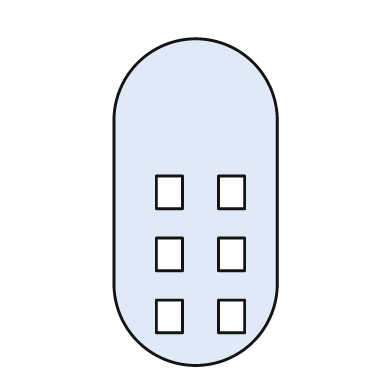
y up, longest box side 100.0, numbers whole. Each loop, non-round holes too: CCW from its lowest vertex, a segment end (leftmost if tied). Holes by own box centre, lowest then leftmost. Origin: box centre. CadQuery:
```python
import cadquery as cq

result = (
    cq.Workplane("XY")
    .moveTo(-25.0, -25.0)
    .threePointArc((0.0, -50.0), (25.0, -25.0))
    .lineTo(25.0, 25.0)
    .threePointArc((0.0, 50.0), (-25.0, 25.0))
    .close()
    .moveTo(-12.0, -40.0)
    .lineTo(-4.0, -40.0)
    .lineTo(-4.0, -30.0)
    .lineTo(-12.0, -30.0)
    .close()
    .moveTo(7.0, -40.0)
    .lineTo(15.0, -40.0)
    .lineTo(15.0, -30.0)
    .lineTo(7.0, -30.0)
    .close()
    .moveTo(-12.0, -21.0)
    .lineTo(-4.0, -21.0)
    .lineTo(-4.0, -11.0)
    .lineTo(-12.0, -11.0)
    .close()
    .moveTo(7.0, -21.0)
    .lineTo(15.0, -21.0)
    .lineTo(15.0, -11.0)
    .lineTo(7.0, -11.0)
    .close()
    .moveTo(-12.0, -2.0)
    .lineTo(-4.0, -2.0)
    .lineTo(-4.0, 8.0)
    .lineTo(-12.0, 8.0)
    .close()
    .moveTo(7.0, -2.0)
    .lineTo(15.0, -2.0)
    .lineTo(15.0, 8.0)
    .lineTo(7.0, 8.0)
    .close()
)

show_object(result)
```